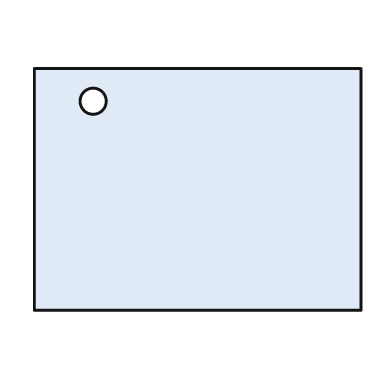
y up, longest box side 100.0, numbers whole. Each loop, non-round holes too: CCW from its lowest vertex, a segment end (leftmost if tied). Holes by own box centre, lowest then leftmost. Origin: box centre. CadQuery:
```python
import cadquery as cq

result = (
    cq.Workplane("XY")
    .moveTo(-50.0, -37.0)
    .lineTo(50.0, -37.0)
    .lineTo(50.0, 37.0)
    .lineTo(-50.0, 37.0)
    .close()
    .moveTo(-32.0, 27.0)
    .circle(4.0)
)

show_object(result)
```